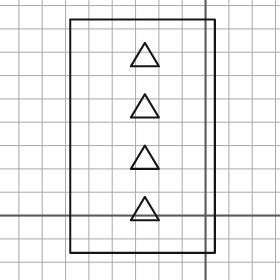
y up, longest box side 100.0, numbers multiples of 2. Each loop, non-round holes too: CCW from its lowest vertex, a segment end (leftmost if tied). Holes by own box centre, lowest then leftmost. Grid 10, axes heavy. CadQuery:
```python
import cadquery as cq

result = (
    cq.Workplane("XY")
    .moveTo(-58.0, -16.0)
    .lineTo(4.0, -16.0)
    .lineTo(4.0, 84.0)
    .lineTo(-58.0, 84.0)
    .close()
    .moveTo(-32.0, -2.0)
    .lineTo(-20.0, -2.0)
    .lineTo(-26.0, 8.0)
    .close()
    .moveTo(-32.0, 20.0)
    .lineTo(-20.0, 20.0)
    .lineTo(-26.0, 30.0)
    .close()
    .moveTo(-32.0, 42.0)
    .lineTo(-20.0, 42.0)
    .lineTo(-26.0, 52.0)
    .close()
    .moveTo(-32.0, 64.0)
    .lineTo(-20.0, 64.0)
    .lineTo(-26.0, 74.0)
    .close()
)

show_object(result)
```